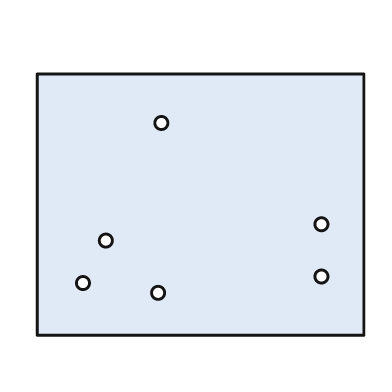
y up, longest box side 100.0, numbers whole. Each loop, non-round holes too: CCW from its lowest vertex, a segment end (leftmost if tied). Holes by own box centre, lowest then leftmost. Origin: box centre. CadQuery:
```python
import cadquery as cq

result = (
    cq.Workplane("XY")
    .moveTo(-50.0, -40.0)
    .lineTo(50.0, -40.0)
    .lineTo(50.0, 40.0)
    .lineTo(-50.0, 40.0)
    .close()
    .moveTo(-13.0, -27.0)
    .circle(2.0)
    .moveTo(-36.0, -24.0)
    .circle(2.0)
    .moveTo(37.0, -22.0)
    .circle(2.0)
    .moveTo(-29.0, -11.0)
    .circle(2.0)
    .moveTo(37.0, -6.0)
    .circle(2.0)
    .moveTo(-12.0, 25.0)
    .circle(2.0)
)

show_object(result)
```